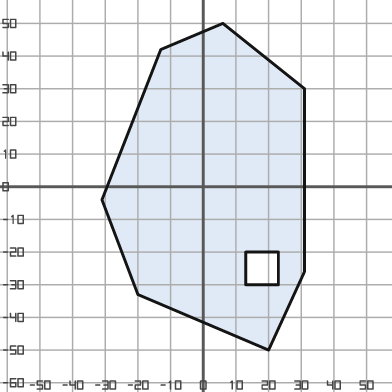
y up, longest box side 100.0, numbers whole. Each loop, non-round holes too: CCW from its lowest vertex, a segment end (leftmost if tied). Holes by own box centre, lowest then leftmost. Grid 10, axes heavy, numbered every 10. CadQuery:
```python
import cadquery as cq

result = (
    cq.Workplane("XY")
    .moveTo(20.0, -50.0)
    .lineTo(31.0, -26.0)
    .lineTo(31.0, 30.0)
    .lineTo(6.0, 50.0)
    .lineTo(-13.0, 42.0)
    .lineTo(-31.0, -4.0)
    .lineTo(-20.0, -33.0)
    .close()
    .moveTo(13.0, -30.0)
    .lineTo(23.0, -30.0)
    .lineTo(23.0, -20.0)
    .lineTo(13.0, -20.0)
    .close()
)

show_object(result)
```